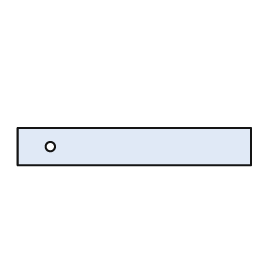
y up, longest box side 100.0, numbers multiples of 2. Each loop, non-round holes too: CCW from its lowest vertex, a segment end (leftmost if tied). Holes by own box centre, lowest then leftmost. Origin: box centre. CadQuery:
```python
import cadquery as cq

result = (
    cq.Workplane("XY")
    .moveTo(-50.0, -8.0)
    .lineTo(50.0, -8.0)
    .lineTo(50.0, 8.0)
    .lineTo(-50.0, 8.0)
    .close()
    .moveTo(-36.0, 0.0)
    .circle(2.0)
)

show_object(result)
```